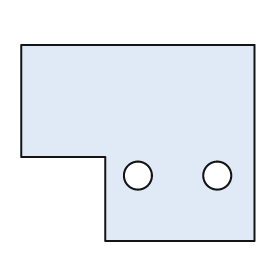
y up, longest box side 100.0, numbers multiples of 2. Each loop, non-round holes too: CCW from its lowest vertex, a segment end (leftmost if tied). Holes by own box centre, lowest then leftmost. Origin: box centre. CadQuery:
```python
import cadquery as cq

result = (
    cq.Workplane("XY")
    .moveTo(-14.0, -42.0)
    .lineTo(50.0, -42.0)
    .lineTo(50.0, 42.0)
    .lineTo(-50.0, 42.0)
    .lineTo(-50.0, -6.0)
    .lineTo(-14.0, -6.0)
    .close()
    .moveTo(0.0, -14.0)
    .circle(6.0)
    .moveTo(34.0, -14.0)
    .circle(6.0)
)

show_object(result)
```